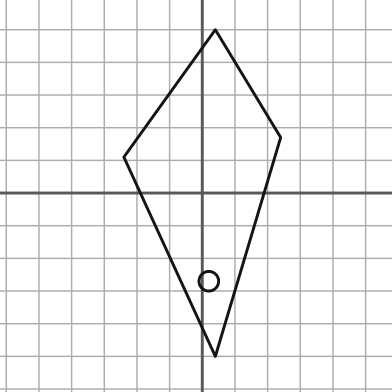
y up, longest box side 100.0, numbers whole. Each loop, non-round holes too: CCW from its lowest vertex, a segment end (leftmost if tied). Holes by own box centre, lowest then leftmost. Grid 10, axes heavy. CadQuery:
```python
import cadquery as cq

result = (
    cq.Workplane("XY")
    .moveTo(4.0, -50.0)
    .lineTo(24.0, 17.0)
    .lineTo(4.0, 50.0)
    .lineTo(-24.0, 11.0)
    .close()
    .moveTo(2.0, -27.0)
    .circle(3.0)
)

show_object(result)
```